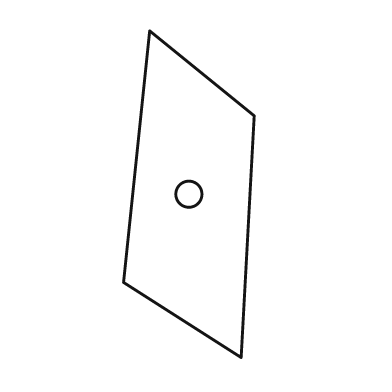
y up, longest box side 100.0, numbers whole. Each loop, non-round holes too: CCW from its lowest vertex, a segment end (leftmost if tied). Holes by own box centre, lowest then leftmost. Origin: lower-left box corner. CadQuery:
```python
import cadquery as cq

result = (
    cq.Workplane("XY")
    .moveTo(36.0, 0.0)
    .lineTo(40.0, 74.0)
    .lineTo(8.0, 100.0)
    .lineTo(0.0, 23.0)
    .close()
    .moveTo(20.0, 50.0)
    .circle(4.0)
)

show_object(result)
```